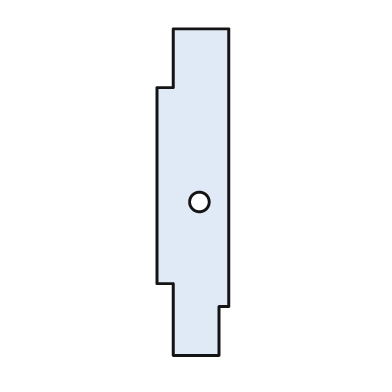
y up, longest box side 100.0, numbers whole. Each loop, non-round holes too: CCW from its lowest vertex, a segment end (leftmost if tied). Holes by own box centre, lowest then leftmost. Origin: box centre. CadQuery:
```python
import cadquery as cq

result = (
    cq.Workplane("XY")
    .moveTo(-6.0, -50.0)
    .lineTo(8.0, -50.0)
    .lineTo(8.0, -35.0)
    .lineTo(11.0, -35.0)
    .lineTo(11.0, 50.0)
    .lineTo(-6.0, 50.0)
    .lineTo(-6.0, 32.0)
    .lineTo(-11.0, 32.0)
    .lineTo(-11.0, -28.0)
    .lineTo(-6.0, -28.0)
    .close()
    .moveTo(2.0, -3.0)
    .circle(3.0)
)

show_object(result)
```